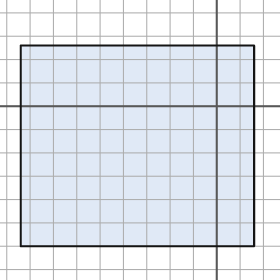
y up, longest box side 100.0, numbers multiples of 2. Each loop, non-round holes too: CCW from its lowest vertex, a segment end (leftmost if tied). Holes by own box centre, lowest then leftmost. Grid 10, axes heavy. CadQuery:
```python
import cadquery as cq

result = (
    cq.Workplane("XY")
    .moveTo(-84.0, -60.0)
    .lineTo(16.0, -60.0)
    .lineTo(16.0, 26.0)
    .lineTo(-84.0, 26.0)
    .close()
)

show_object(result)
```